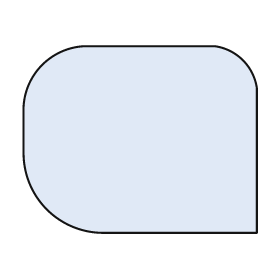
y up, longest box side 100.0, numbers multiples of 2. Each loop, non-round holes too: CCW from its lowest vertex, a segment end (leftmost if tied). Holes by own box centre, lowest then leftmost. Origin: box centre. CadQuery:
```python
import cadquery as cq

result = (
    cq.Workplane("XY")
    .moveTo(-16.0, -40.0)
    .lineTo(50.0, -40.0)
    .lineTo(50.0, 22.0)
    .threePointArc((44.0, 34.0), (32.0, 40.0))
    .lineTo(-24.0, 40.0)
    .threePointArc((-42.0, 32.0), (-50.0, 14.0))
    .lineTo(-50.0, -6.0)
    .threePointArc((-40.0, -30.0), (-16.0, -40.0))
    .close()
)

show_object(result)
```